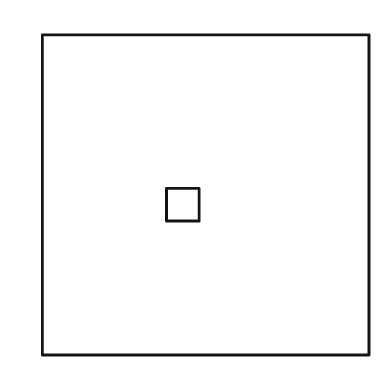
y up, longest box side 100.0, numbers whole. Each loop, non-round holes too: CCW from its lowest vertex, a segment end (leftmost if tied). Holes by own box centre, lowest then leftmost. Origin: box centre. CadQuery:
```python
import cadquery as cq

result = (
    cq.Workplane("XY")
    .moveTo(-50.0, -49.0)
    .lineTo(50.0, -49.0)
    .lineTo(50.0, 49.0)
    .lineTo(-50.0, 49.0)
    .close()
    .moveTo(-12.0, -8.0)
    .lineTo(-2.0, -8.0)
    .lineTo(-2.0, 2.0)
    .lineTo(-12.0, 2.0)
    .close()
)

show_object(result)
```